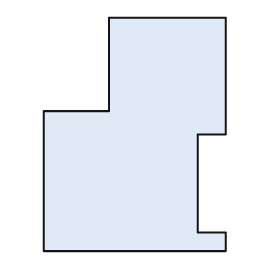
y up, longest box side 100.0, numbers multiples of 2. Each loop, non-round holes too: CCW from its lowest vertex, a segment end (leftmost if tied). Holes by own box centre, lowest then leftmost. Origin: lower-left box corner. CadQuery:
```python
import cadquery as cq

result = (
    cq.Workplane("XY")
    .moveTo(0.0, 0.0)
    .lineTo(78.0, 0.0)
    .lineTo(78.0, 8.0)
    .lineTo(66.0, 8.0)
    .lineTo(66.0, 50.0)
    .lineTo(78.0, 50.0)
    .lineTo(78.0, 100.0)
    .lineTo(28.0, 100.0)
    .lineTo(28.0, 60.0)
    .lineTo(0.0, 60.0)
    .close()
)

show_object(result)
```